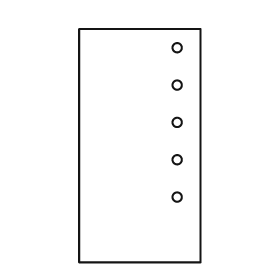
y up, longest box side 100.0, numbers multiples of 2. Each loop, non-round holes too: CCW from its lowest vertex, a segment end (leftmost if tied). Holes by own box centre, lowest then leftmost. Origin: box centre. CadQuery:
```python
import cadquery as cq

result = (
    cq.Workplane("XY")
    .moveTo(-26.0, -50.0)
    .lineTo(26.0, -50.0)
    .lineTo(26.0, 50.0)
    .lineTo(-26.0, 50.0)
    .close()
    .moveTo(16.0, -22.0)
    .circle(2.0)
    .moveTo(16.0, -6.0)
    .circle(2.0)
    .moveTo(16.0, 10.0)
    .circle(2.0)
    .moveTo(16.0, 26.0)
    .circle(2.0)
    .moveTo(16.0, 42.0)
    .circle(2.0)
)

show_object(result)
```